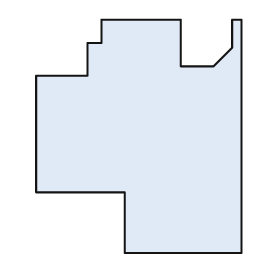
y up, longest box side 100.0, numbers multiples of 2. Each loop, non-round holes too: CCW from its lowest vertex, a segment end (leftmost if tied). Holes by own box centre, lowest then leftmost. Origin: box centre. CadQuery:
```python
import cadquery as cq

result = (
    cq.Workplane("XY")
    .moveTo(-6.0, -50.0)
    .lineTo(44.0, -50.0)
    .lineTo(44.0, 50.0)
    .lineTo(40.0, 50.0)
    .lineTo(40.0, 38.0)
    .lineTo(32.0, 30.0)
    .lineTo(18.0, 30.0)
    .lineTo(18.0, 50.0)
    .lineTo(-16.0, 50.0)
    .lineTo(-16.0, 40.0)
    .lineTo(-22.0, 40.0)
    .lineTo(-22.0, 26.0)
    .lineTo(-44.0, 26.0)
    .lineTo(-44.0, -24.0)
    .lineTo(-6.0, -24.0)
    .close()
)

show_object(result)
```